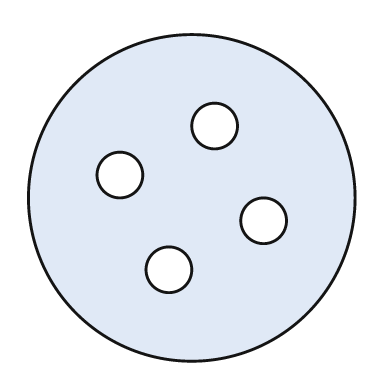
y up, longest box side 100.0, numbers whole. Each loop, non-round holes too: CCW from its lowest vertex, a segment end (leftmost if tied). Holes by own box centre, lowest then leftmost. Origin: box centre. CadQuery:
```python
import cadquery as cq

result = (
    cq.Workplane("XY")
    .moveTo(0.0, 0.0)
    .circle(50.0)
    .moveTo(-7.0, -22.0)
    .circle(7.0)
    .moveTo(22.0, -7.0)
    .circle(7.0)
    .moveTo(-22.0, 7.0)
    .circle(7.0)
    .moveTo(7.0, 22.0)
    .circle(7.0)
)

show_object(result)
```